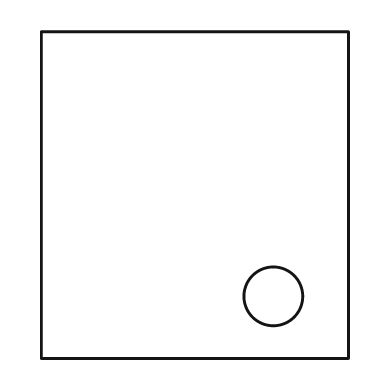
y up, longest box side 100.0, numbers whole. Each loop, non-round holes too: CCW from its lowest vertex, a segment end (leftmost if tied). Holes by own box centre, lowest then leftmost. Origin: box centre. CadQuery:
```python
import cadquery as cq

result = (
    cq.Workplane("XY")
    .moveTo(-47.0, -50.0)
    .lineTo(47.0, -50.0)
    .lineTo(47.0, 50.0)
    .lineTo(-47.0, 50.0)
    .close()
    .moveTo(24.0, -31.0)
    .circle(9.0)
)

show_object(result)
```